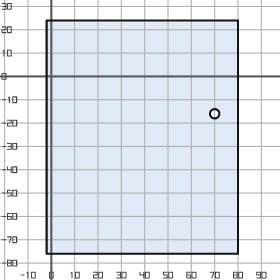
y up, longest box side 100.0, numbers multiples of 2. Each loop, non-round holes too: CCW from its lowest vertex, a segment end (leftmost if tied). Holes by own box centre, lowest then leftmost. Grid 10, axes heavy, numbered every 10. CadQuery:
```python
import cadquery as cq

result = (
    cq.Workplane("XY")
    .moveTo(-2.0, -76.0)
    .lineTo(80.0, -76.0)
    .lineTo(80.0, 24.0)
    .lineTo(-2.0, 24.0)
    .close()
    .moveTo(70.0, -16.0)
    .circle(2.0)
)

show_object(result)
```